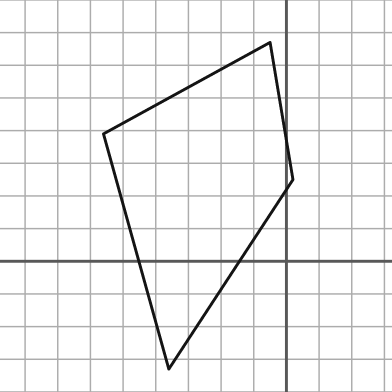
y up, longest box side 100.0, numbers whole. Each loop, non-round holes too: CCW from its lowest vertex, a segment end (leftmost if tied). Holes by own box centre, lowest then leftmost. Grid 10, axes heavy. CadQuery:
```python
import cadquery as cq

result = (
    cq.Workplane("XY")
    .moveTo(-36.0, -33.0)
    .lineTo(2.0, 25.0)
    .lineTo(-5.0, 67.0)
    .lineTo(-56.0, 39.0)
    .close()
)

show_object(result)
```